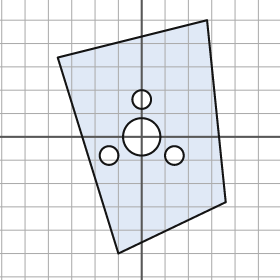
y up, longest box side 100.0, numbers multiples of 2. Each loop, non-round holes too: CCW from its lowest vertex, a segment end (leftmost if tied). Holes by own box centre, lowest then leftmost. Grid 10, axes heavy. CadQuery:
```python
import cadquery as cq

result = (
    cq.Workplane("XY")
    .moveTo(-10.0, -50.0)
    .lineTo(36.0, -28.0)
    .lineTo(28.0, 50.0)
    .lineTo(-36.0, 34.0)
    .close()
    .moveTo(-14.0, -8.0)
    .circle(4.0)
    .moveTo(14.0, -8.0)
    .circle(4.0)
    .moveTo(0.0, 0.0)
    .circle(8.0)
    .moveTo(0.0, 16.0)
    .circle(4.0)
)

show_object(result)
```